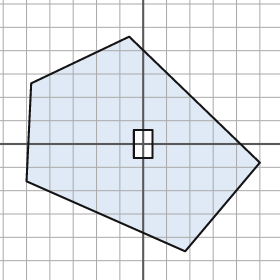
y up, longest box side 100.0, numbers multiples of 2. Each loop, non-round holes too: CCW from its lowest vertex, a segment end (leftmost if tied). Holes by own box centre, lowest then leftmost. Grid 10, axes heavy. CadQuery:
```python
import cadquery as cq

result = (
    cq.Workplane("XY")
    .moveTo(18.0, -46.0)
    .lineTo(50.0, -8.0)
    .lineTo(-6.0, 46.0)
    .lineTo(-48.0, 26.0)
    .lineTo(-50.0, -16.0)
    .close()
    .moveTo(-4.0, -6.0)
    .lineTo(4.0, -6.0)
    .lineTo(4.0, 6.0)
    .lineTo(-4.0, 6.0)
    .close()
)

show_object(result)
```